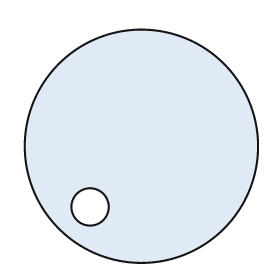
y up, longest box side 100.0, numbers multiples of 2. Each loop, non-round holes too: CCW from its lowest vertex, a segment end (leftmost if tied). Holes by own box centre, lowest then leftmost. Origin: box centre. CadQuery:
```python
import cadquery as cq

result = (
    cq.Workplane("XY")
    .moveTo(0.0, 0.0)
    .circle(50.0)
    .moveTo(-22.0, -26.0)
    .circle(8.0)
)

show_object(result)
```